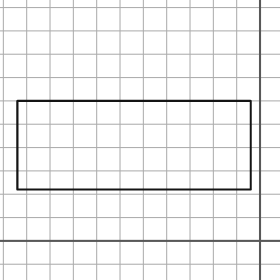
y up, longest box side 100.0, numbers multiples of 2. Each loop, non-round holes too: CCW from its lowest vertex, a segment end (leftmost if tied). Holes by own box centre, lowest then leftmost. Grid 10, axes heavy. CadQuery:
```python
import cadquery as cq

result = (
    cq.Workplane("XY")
    .moveTo(-104.0, 22.0)
    .lineTo(-4.0, 22.0)
    .lineTo(-4.0, 60.0)
    .lineTo(-104.0, 60.0)
    .close()
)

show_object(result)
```